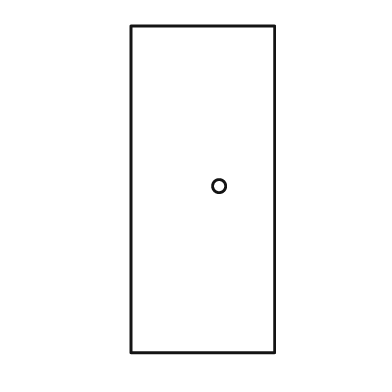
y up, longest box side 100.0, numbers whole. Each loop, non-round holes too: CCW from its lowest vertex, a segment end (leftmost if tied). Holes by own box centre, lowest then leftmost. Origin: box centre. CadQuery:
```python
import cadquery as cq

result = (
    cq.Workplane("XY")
    .moveTo(-22.0, -50.0)
    .lineTo(22.0, -50.0)
    .lineTo(22.0, 50.0)
    .lineTo(-22.0, 50.0)
    .close()
    .moveTo(5.0, 1.0)
    .circle(2.0)
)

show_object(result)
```